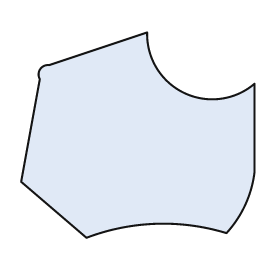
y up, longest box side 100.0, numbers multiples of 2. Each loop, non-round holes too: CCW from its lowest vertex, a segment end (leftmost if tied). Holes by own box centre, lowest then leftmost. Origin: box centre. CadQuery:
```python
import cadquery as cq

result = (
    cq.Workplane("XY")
    .moveTo(-22.0, -44.0)
    .threePointArc((8.0, -38.0), (38.0, -42.0))
    .threePointArc((46.0, -30.0), (50.0, -16.0))
    .lineTo(50.0, 22.0)
    .threePointArc((20.0, 18.0), (4.0, 44.0))
    .lineTo(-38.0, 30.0)
    .threePointArc((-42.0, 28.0), (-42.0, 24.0))
    .lineTo(-50.0, -20.0)
    .close()
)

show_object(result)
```